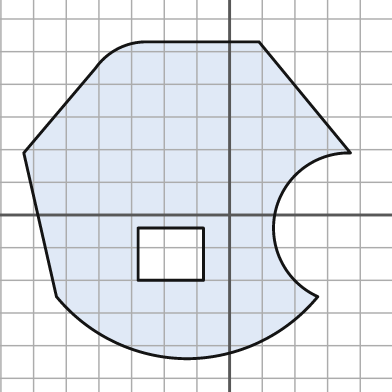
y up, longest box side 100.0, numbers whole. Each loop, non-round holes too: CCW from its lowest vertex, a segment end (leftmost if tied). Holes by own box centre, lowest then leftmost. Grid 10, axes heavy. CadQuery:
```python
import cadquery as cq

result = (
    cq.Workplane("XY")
    .moveTo(-13.0, -44.0)
    .threePointArc((9.0, -39.0), (27.0, -25.0))
    .threePointArc((14.0, 1.0), (37.0, 19.0))
    .lineTo(9.0, 53.0)
    .lineTo(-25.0, 53.0)
    .threePointArc((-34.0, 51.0), (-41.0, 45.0))
    .lineTo(-63.0, 19.0)
    .lineTo(-53.0, -25.0)
    .threePointArc((-35.0, -39.0), (-13.0, -44.0))
    .close()
    .moveTo(-28.0, -20.0)
    .lineTo(-8.0, -20.0)
    .lineTo(-8.0, -4.0)
    .lineTo(-28.0, -4.0)
    .close()
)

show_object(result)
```